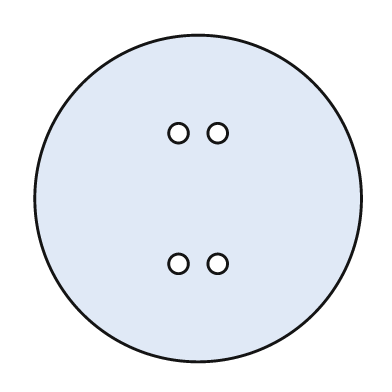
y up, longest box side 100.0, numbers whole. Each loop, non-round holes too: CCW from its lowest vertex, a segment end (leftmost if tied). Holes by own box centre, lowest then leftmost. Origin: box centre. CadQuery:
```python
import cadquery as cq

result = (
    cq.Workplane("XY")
    .moveTo(0.0, 0.0)
    .circle(50.0)
    .moveTo(-6.0, -20.0)
    .circle(3.0)
    .moveTo(6.0, -20.0)
    .circle(3.0)
    .moveTo(-6.0, 20.0)
    .circle(3.0)
    .moveTo(6.0, 20.0)
    .circle(3.0)
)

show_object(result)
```